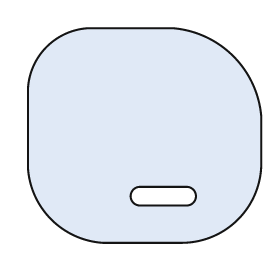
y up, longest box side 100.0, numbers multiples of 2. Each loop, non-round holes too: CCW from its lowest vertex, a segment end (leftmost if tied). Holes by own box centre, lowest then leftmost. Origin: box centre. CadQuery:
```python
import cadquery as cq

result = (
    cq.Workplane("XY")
    .moveTo(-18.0, -46.0)
    .lineTo(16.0, -46.0)
    .threePointArc((40.0, -36.0), (50.0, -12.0))
    .lineTo(50.0, 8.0)
    .threePointArc((38.0, 34.0), (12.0, 46.0))
    .lineTo(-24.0, 46.0)
    .threePointArc((-42.0, 38.0), (-50.0, 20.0))
    .lineTo(-50.0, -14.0)
    .threePointArc((-40.0, -36.0), (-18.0, -46.0))
    .close()
    .moveTo(-2.0, -30.0)
    .lineTo(18.0, -30.0)
    .threePointArc((22.0, -26.0), (18.0, -22.0))
    .lineTo(-2.0, -22.0)
    .threePointArc((-6.0, -26.0), (-2.0, -30.0))
    .close()
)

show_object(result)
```